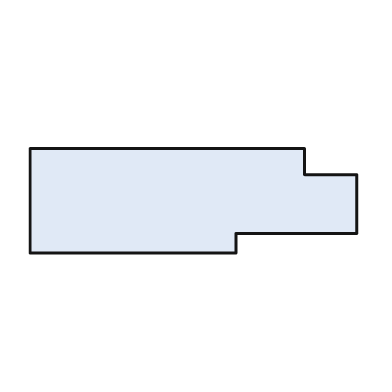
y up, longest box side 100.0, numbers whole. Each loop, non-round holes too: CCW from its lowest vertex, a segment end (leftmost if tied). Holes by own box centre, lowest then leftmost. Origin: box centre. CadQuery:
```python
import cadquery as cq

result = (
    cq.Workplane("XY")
    .moveTo(-50.0, -16.0)
    .lineTo(13.0, -16.0)
    .lineTo(13.0, -10.0)
    .lineTo(50.0, -10.0)
    .lineTo(50.0, 8.0)
    .lineTo(34.0, 8.0)
    .lineTo(34.0, 16.0)
    .lineTo(-50.0, 16.0)
    .close()
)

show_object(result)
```